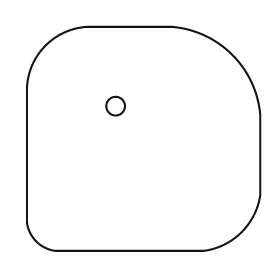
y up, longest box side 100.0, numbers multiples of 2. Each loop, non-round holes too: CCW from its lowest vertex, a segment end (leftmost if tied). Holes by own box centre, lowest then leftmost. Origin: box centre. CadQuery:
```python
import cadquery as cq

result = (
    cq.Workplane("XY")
    .moveTo(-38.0, -48.0)
    .lineTo(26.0, -48.0)
    .threePointArc((42.0, -40.0), (50.0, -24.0))
    .lineTo(50.0, 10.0)
    .threePointArc((38.0, 36.0), (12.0, 48.0))
    .lineTo(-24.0, 48.0)
    .threePointArc((-42.0, 40.0), (-50.0, 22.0))
    .lineTo(-50.0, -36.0)
    .threePointArc((-46.0, -44.0), (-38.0, -48.0))
    .close()
    .moveTo(-12.0, 14.0)
    .circle(4.0)
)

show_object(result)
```